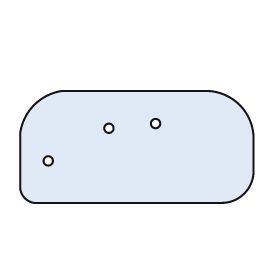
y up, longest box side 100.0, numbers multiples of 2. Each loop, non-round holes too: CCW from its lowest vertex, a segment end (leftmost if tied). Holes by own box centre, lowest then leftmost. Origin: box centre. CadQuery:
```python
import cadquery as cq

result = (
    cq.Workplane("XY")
    .moveTo(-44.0, -24.0)
    .lineTo(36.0, -24.0)
    .threePointArc((46.0, -20.0), (50.0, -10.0))
    .lineTo(50.0, 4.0)
    .threePointArc((44.0, 18.0), (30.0, 24.0))
    .lineTo(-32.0, 24.0)
    .threePointArc((-44.0, 18.0), (-50.0, 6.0))
    .lineTo(-50.0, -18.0)
    .threePointArc((-48.0, -22.0), (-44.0, -24.0))
    .close()
    .moveTo(-38.0, -6.0)
    .circle(2.0)
    .moveTo(-12.0, 8.0)
    .circle(2.0)
    .moveTo(8.0, 10.0)
    .circle(2.0)
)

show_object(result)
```